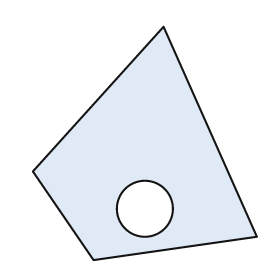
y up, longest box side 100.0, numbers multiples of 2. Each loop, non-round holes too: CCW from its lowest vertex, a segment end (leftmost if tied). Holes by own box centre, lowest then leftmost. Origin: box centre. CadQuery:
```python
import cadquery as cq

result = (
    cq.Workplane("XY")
    .moveTo(-22.0, -50.0)
    .lineTo(48.0, -40.0)
    .lineTo(8.0, 50.0)
    .lineTo(-48.0, -12.0)
    .close()
    .moveTo(0.0, -28.0)
    .circle(12.0)
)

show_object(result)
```